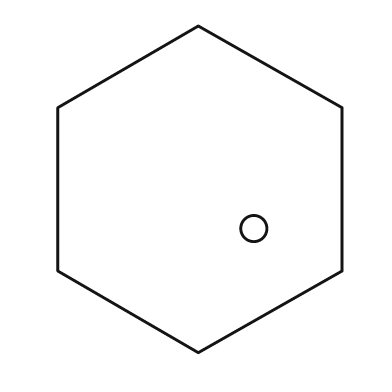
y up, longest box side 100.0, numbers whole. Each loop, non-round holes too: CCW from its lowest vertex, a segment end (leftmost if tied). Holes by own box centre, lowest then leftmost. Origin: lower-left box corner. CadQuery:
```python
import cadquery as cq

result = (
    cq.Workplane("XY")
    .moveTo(43.0, 0.0)
    .lineTo(87.0, 25.0)
    .lineTo(87.0, 75.0)
    .lineTo(43.0, 100.0)
    .lineTo(0.0, 75.0)
    .lineTo(0.0, 25.0)
    .close()
    .moveTo(60.0, 38.0)
    .circle(4.0)
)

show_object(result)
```